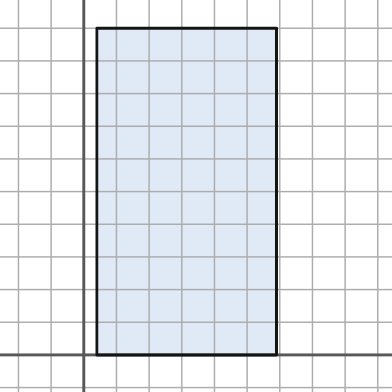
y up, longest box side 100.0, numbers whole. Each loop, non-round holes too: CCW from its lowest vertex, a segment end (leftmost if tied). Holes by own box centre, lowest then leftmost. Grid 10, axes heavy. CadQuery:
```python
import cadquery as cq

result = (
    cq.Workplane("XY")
    .moveTo(4.0, 0.0)
    .lineTo(59.0, 0.0)
    .lineTo(59.0, 100.0)
    .lineTo(4.0, 100.0)
    .close()
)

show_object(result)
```